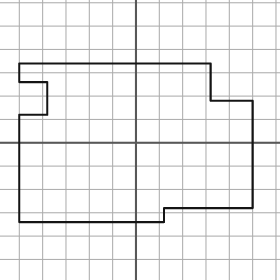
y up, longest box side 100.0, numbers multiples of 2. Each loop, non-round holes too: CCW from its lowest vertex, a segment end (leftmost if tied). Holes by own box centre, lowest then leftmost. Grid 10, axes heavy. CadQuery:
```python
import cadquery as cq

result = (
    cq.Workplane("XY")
    .moveTo(-50.0, -34.0)
    .lineTo(12.0, -34.0)
    .lineTo(12.0, -28.0)
    .lineTo(50.0, -28.0)
    .lineTo(50.0, 18.0)
    .lineTo(32.0, 18.0)
    .lineTo(32.0, 34.0)
    .lineTo(-50.0, 34.0)
    .lineTo(-50.0, 26.0)
    .lineTo(-38.0, 26.0)
    .lineTo(-38.0, 12.0)
    .lineTo(-50.0, 12.0)
    .close()
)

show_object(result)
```